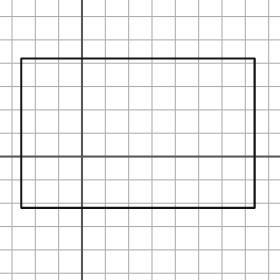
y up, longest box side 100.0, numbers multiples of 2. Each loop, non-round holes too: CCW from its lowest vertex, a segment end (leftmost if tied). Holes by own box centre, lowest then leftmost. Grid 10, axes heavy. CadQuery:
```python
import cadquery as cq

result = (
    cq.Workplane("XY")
    .moveTo(-26.0, -22.0)
    .lineTo(74.0, -22.0)
    .lineTo(74.0, 42.0)
    .lineTo(-26.0, 42.0)
    .close()
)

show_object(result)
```